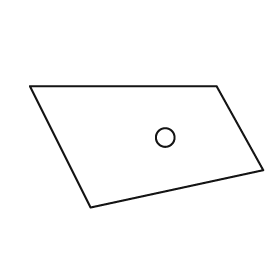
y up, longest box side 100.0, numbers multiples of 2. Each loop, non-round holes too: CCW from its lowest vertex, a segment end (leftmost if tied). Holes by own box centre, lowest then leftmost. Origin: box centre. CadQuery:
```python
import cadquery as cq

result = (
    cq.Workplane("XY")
    .moveTo(-24.0, -26.0)
    .lineTo(50.0, -10.0)
    .lineTo(30.0, 26.0)
    .lineTo(-50.0, 26.0)
    .close()
    .moveTo(8.0, 4.0)
    .circle(4.0)
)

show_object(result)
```